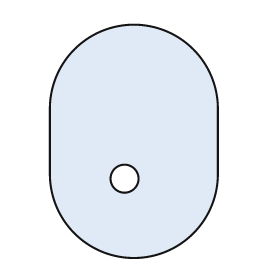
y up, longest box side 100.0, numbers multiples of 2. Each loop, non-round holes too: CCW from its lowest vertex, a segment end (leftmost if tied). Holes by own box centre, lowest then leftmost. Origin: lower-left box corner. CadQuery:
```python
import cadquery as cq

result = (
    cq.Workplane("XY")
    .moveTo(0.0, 36.0)
    .threePointArc((36.0, 0.0), (72.0, 36.0))
    .lineTo(72.0, 64.0)
    .threePointArc((36.0, 100.0), (0.0, 64.0))
    .close()
    .moveTo(32.0, 34.0)
    .circle(6.0)
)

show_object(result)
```